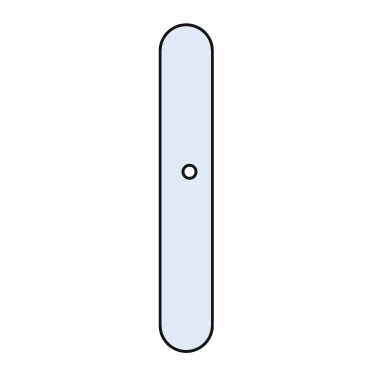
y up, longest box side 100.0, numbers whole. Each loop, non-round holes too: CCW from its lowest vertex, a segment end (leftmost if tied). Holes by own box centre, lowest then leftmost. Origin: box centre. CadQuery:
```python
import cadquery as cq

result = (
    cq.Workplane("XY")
    .moveTo(-8.0, -42.0)
    .threePointArc((0.0, -50.0), (8.0, -42.0))
    .lineTo(8.0, 42.0)
    .threePointArc((0.0, 50.0), (-8.0, 42.0))
    .close()
    .moveTo(1.0, 5.0)
    .circle(2.0)
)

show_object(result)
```